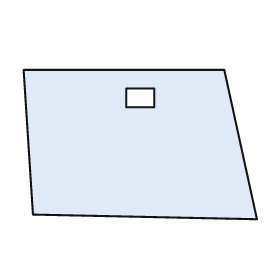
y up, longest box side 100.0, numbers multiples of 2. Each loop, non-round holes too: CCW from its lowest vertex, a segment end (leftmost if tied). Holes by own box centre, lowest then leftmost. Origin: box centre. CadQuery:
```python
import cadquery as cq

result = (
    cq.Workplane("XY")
    .moveTo(50.0, -32.0)
    .lineTo(36.0, 32.0)
    .lineTo(-50.0, 32.0)
    .lineTo(-46.0, -30.0)
    .close()
    .moveTo(-6.0, 16.0)
    .lineTo(6.0, 16.0)
    .lineTo(6.0, 24.0)
    .lineTo(-6.0, 24.0)
    .close()
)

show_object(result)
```